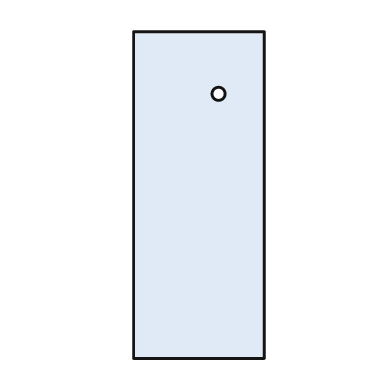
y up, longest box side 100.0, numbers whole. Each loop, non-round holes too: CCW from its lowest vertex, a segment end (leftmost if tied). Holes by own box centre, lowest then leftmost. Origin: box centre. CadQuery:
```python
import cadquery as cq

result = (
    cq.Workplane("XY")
    .moveTo(-20.0, -50.0)
    .lineTo(20.0, -50.0)
    .lineTo(20.0, 50.0)
    .lineTo(-20.0, 50.0)
    .close()
    .moveTo(6.0, 31.0)
    .circle(2.0)
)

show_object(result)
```